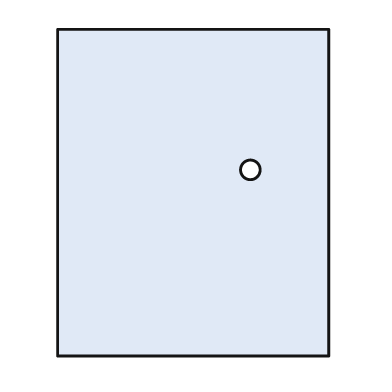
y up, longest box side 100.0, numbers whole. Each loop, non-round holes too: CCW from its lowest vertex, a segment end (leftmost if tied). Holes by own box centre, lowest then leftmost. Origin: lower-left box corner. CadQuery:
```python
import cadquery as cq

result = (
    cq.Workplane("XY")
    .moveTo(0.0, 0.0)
    .lineTo(83.0, 0.0)
    .lineTo(83.0, 100.0)
    .lineTo(0.0, 100.0)
    .close()
    .moveTo(59.0, 57.0)
    .circle(3.0)
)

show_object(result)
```